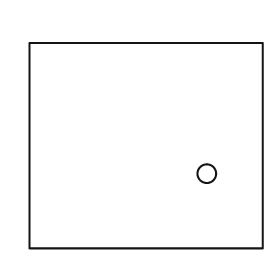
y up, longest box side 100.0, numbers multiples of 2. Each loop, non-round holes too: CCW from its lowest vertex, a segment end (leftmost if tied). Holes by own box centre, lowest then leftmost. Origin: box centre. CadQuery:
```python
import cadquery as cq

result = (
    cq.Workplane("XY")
    .moveTo(-50.0, -44.0)
    .lineTo(50.0, -44.0)
    .lineTo(50.0, 44.0)
    .lineTo(-50.0, 44.0)
    .close()
    .moveTo(26.0, -12.0)
    .circle(4.0)
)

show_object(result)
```